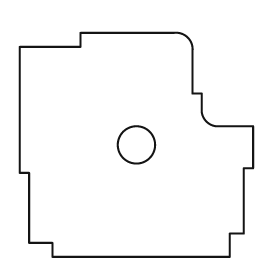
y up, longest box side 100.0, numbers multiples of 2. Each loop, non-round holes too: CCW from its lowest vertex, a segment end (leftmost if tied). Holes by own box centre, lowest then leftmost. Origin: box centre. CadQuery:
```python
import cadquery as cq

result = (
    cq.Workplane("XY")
    .moveTo(-36.0, -48.0)
    .lineTo(40.0, -48.0)
    .lineTo(40.0, -38.0)
    .lineTo(46.0, -38.0)
    .lineTo(46.0, -10.0)
    .lineTo(50.0, -10.0)
    .lineTo(50.0, 8.0)
    .lineTo(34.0, 8.0)
    .threePointArc((30.0, 10.0), (28.0, 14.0))
    .lineTo(28.0, 22.0)
    .lineTo(24.0, 22.0)
    .lineTo(24.0, 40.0)
    .threePointArc((22.0, 46.0), (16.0, 48.0))
    .lineTo(-24.0, 48.0)
    .lineTo(-24.0, 42.0)
    .lineTo(-50.0, 42.0)
    .lineTo(-50.0, -12.0)
    .lineTo(-46.0, -12.0)
    .lineTo(-46.0, -42.0)
    .lineTo(-36.0, -42.0)
    .close()
    .moveTo(0.0, 0.0)
    .circle(8.0)
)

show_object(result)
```